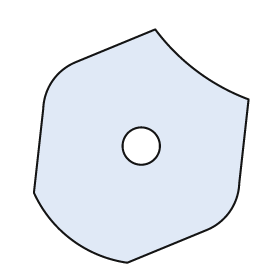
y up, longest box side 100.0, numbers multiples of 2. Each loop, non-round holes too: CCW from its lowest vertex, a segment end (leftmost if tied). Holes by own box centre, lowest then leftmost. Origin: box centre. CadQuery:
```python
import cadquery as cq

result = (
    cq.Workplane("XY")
    .moveTo(-6.0, -50.0)
    .lineTo(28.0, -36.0)
    .threePointArc((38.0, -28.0), (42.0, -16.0))
    .lineTo(46.0, 20.0)
    .threePointArc((24.0, 32.0), (6.0, 50.0))
    .lineTo(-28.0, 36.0)
    .threePointArc((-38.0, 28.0), (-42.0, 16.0))
    .lineTo(-46.0, -20.0)
    .threePointArc((-30.0, -40.0), (-6.0, -50.0))
    .close()
    .moveTo(0.0, 0.0)
    .circle(8.0)
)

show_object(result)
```